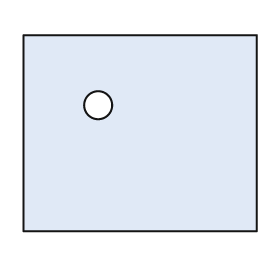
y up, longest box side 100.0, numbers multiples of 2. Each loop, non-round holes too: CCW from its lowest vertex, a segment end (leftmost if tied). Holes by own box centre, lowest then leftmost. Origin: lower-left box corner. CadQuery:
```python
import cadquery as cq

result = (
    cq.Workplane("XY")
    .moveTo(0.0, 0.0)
    .lineTo(100.0, 0.0)
    .lineTo(100.0, 84.0)
    .lineTo(0.0, 84.0)
    .close()
    .moveTo(32.0, 54.0)
    .circle(6.0)
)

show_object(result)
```